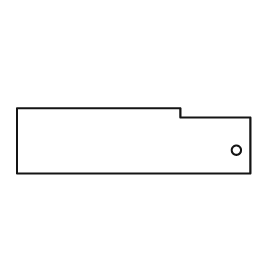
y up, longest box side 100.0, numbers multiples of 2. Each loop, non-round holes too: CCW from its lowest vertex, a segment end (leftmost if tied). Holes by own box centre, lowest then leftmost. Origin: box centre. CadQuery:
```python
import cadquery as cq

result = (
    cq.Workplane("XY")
    .moveTo(-50.0, -14.0)
    .lineTo(50.0, -14.0)
    .lineTo(50.0, 10.0)
    .lineTo(20.0, 10.0)
    .lineTo(20.0, 14.0)
    .lineTo(-50.0, 14.0)
    .close()
    .moveTo(44.0, -4.0)
    .circle(2.0)
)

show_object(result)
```